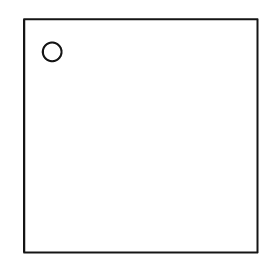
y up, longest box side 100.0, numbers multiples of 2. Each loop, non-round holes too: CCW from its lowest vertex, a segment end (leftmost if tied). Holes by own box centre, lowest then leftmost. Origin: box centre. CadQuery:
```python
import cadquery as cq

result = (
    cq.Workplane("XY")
    .moveTo(-50.0, -50.0)
    .lineTo(50.0, -50.0)
    .lineTo(50.0, 50.0)
    .lineTo(-50.0, 50.0)
    .close()
    .moveTo(-38.0, 36.0)
    .circle(4.0)
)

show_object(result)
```